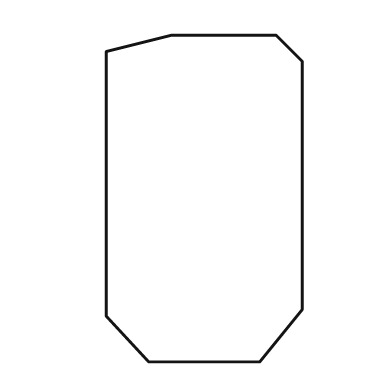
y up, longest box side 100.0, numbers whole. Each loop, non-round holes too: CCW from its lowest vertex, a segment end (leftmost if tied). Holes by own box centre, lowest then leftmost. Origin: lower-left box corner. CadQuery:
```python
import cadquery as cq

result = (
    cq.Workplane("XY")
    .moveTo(13.0, 0.0)
    .lineTo(47.0, 0.0)
    .lineTo(60.0, 16.0)
    .lineTo(60.0, 92.0)
    .lineTo(52.0, 100.0)
    .lineTo(20.0, 100.0)
    .lineTo(0.0, 95.0)
    .lineTo(0.0, 14.0)
    .close()
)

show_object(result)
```